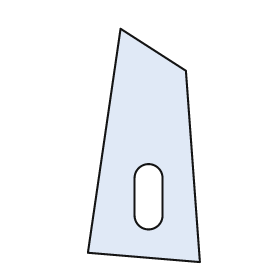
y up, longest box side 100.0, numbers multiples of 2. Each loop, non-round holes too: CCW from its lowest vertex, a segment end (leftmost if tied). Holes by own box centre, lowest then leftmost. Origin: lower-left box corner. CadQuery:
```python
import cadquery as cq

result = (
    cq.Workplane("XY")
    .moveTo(48.0, 0.0)
    .lineTo(42.0, 82.0)
    .lineTo(14.0, 100.0)
    .lineTo(0.0, 4.0)
    .close()
    .moveTo(20.0, 20.0)
    .threePointArc((26.0, 14.0), (32.0, 20.0))
    .lineTo(32.0, 36.0)
    .threePointArc((26.0, 42.0), (20.0, 36.0))
    .close()
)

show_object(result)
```